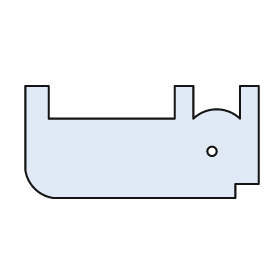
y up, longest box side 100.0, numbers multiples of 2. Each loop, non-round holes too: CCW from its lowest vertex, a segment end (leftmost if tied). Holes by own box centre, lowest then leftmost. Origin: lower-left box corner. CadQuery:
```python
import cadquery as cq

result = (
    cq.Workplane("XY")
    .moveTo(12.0, 0.0)
    .lineTo(90.0, 0.0)
    .lineTo(90.0, 6.0)
    .lineTo(100.0, 6.0)
    .lineTo(100.0, 48.0)
    .lineTo(92.0, 48.0)
    .lineTo(92.0, 34.0)
    .threePointArc((82.0, 38.0), (72.0, 34.0))
    .lineTo(72.0, 48.0)
    .lineTo(64.0, 48.0)
    .lineTo(64.0, 34.0)
    .lineTo(10.0, 34.0)
    .lineTo(10.0, 48.0)
    .lineTo(0.0, 48.0)
    .lineTo(0.0, 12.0)
    .threePointArc((4.0, 4.0), (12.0, 0.0))
    .close()
    .moveTo(80.0, 20.0)
    .circle(2.0)
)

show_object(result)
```